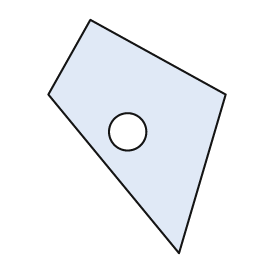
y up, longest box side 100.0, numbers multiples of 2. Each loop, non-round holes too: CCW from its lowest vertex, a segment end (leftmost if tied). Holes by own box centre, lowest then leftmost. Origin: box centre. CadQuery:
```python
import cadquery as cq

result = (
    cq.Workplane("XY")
    .moveTo(18.0, -50.0)
    .lineTo(38.0, 18.0)
    .lineTo(-20.0, 50.0)
    .lineTo(-38.0, 18.0)
    .close()
    .moveTo(-4.0, 2.0)
    .circle(8.0)
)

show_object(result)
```